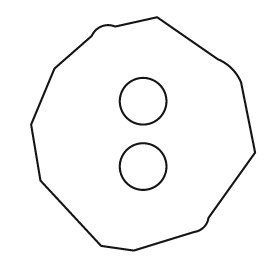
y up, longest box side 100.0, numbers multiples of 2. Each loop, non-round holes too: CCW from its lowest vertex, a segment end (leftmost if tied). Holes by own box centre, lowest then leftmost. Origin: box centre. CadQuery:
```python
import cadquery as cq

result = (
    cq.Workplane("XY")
    .moveTo(-4.0, -50.0)
    .lineTo(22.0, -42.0)
    .threePointArc((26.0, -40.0), (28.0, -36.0))
    .lineTo(48.0, -8.0)
    .lineTo(42.0, 22.0)
    .threePointArc((38.0, 28.0), (32.0, 32.0))
    .lineTo(6.0, 50.0)
    .lineTo(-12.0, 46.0)
    .threePointArc((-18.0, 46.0), (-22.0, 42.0))
    .lineTo(-38.0, 28.0)
    .lineTo(-48.0, 4.0)
    .lineTo(-44.0, -20.0)
    .lineTo(-18.0, -48.0)
    .close()
    .moveTo(0.0, -14.0)
    .circle(10.0)
    .moveTo(0.0, 14.0)
    .circle(10.0)
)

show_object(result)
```